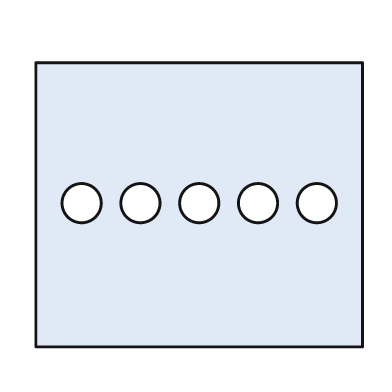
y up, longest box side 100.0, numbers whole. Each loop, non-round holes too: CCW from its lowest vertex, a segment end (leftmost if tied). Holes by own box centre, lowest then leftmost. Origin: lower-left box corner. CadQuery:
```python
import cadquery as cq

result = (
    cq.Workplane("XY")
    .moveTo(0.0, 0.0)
    .lineTo(100.0, 0.0)
    .lineTo(100.0, 87.0)
    .lineTo(0.0, 87.0)
    .close()
    .moveTo(14.0, 44.0)
    .circle(6.0)
    .moveTo(32.0, 44.0)
    .circle(6.0)
    .moveTo(50.0, 44.0)
    .circle(6.0)
    .moveTo(68.0, 44.0)
    .circle(6.0)
    .moveTo(86.0, 44.0)
    .circle(6.0)
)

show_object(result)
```